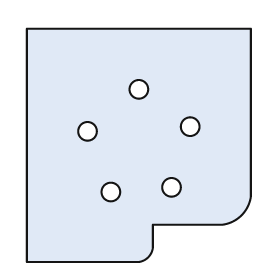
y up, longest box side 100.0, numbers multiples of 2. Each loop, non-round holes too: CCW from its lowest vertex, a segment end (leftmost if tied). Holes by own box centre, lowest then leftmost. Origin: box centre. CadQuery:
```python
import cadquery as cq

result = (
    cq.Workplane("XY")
    .moveTo(-48.0, -50.0)
    .lineTo(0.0, -50.0)
    .threePointArc((4.0, -48.0), (6.0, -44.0))
    .lineTo(6.0, -34.0)
    .lineTo(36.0, -34.0)
    .threePointArc((44.0, -30.0), (48.0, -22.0))
    .lineTo(48.0, 50.0)
    .lineTo(-48.0, 50.0)
    .close()
    .moveTo(-12.0, -20.0)
    .circle(4.0)
    .moveTo(14.0, -18.0)
    .circle(4.0)
    .moveTo(-22.0, 6.0)
    .circle(4.0)
    .moveTo(22.0, 8.0)
    .circle(4.0)
    .moveTo(0.0, 24.0)
    .circle(4.0)
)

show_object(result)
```